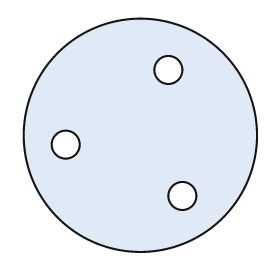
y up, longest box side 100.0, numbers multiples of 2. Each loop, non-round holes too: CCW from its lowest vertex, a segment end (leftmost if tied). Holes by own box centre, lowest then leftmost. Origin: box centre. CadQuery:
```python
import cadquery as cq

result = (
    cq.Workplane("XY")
    .moveTo(0.0, 0.0)
    .circle(50.0)
    .moveTo(18.0, -26.0)
    .circle(6.0)
    .moveTo(-32.0, -4.0)
    .circle(6.0)
    .moveTo(12.0, 28.0)
    .circle(6.0)
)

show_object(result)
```